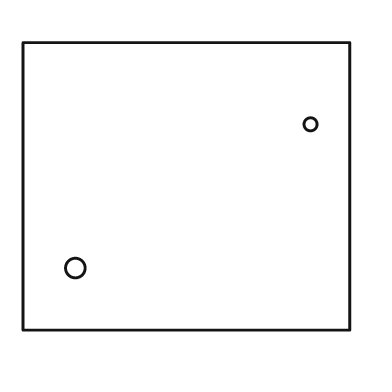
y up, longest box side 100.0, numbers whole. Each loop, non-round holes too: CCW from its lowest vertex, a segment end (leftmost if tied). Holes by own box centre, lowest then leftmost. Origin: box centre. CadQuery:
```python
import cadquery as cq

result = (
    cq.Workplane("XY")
    .moveTo(-50.0, -44.0)
    .lineTo(50.0, -44.0)
    .lineTo(50.0, 44.0)
    .lineTo(-50.0, 44.0)
    .close()
    .moveTo(-34.0, -25.0)
    .circle(3.0)
    .moveTo(38.0, 19.0)
    .circle(2.0)
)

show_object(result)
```